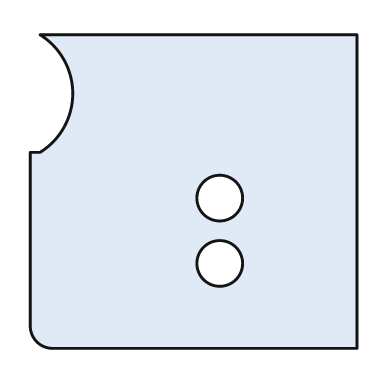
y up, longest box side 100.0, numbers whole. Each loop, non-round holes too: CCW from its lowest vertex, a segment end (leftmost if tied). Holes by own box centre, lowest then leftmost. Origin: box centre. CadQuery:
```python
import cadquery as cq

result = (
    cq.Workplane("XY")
    .moveTo(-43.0, -48.0)
    .lineTo(50.0, -48.0)
    .lineTo(50.0, 48.0)
    .lineTo(-47.0, 48.0)
    .threePointArc((-37.0, 30.0), (-47.0, 12.0))
    .lineTo(-50.0, 12.0)
    .lineTo(-50.0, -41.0)
    .threePointArc((-48.0, -46.0), (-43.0, -48.0))
    .close()
    .moveTo(8.0, -22.0)
    .circle(7.0)
    .moveTo(8.0, -2.0)
    .circle(7.0)
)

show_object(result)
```